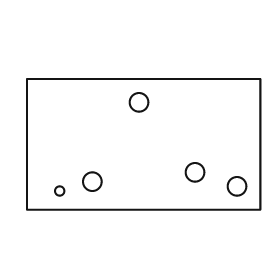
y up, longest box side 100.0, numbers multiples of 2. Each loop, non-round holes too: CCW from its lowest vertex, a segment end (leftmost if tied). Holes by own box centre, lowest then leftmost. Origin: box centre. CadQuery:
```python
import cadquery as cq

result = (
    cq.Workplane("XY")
    .moveTo(-50.0, -28.0)
    .lineTo(50.0, -28.0)
    .lineTo(50.0, 28.0)
    .lineTo(-50.0, 28.0)
    .close()
    .moveTo(-36.0, -20.0)
    .circle(2.0)
    .moveTo(40.0, -18.0)
    .circle(4.0)
    .moveTo(-22.0, -16.0)
    .circle(4.0)
    .moveTo(22.0, -12.0)
    .circle(4.0)
    .moveTo(-2.0, 18.0)
    .circle(4.0)
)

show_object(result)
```